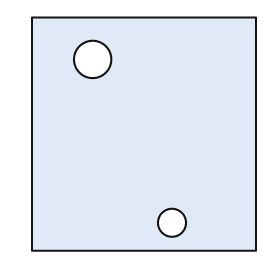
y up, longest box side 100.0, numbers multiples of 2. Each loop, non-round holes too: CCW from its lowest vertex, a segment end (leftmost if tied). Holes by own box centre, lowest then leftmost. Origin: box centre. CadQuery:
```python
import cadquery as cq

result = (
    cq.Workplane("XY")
    .moveTo(-48.0, -50.0)
    .lineTo(48.0, -50.0)
    .lineTo(48.0, 50.0)
    .lineTo(-48.0, 50.0)
    .close()
    .moveTo(12.0, -38.0)
    .circle(6.0)
    .moveTo(-22.0, 32.0)
    .circle(8.0)
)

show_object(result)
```